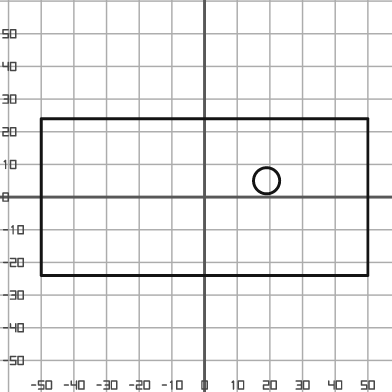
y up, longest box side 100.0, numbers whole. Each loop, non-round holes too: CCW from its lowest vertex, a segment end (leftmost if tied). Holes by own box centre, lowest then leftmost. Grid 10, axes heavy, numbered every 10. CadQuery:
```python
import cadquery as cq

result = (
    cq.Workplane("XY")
    .moveTo(-50.0, -24.0)
    .lineTo(50.0, -24.0)
    .lineTo(50.0, 24.0)
    .lineTo(-50.0, 24.0)
    .close()
    .moveTo(19.0, 5.0)
    .circle(4.0)
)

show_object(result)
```